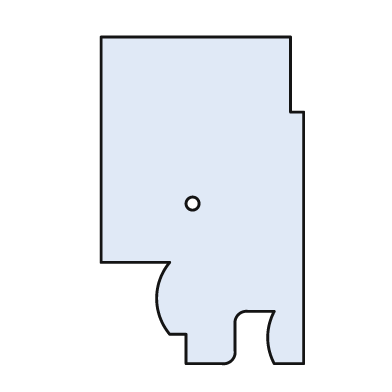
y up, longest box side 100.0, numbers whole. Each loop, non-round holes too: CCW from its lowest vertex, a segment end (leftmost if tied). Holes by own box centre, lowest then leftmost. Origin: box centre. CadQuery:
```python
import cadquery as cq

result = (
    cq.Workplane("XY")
    .moveTo(-5.0, -50.0)
    .lineTo(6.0, -50.0)
    .threePointArc((9.0, -49.0), (10.0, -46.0))
    .lineTo(10.0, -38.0)
    .threePointArc((11.0, -35.0), (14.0, -34.0))
    .lineTo(22.0, -34.0)
    .threePointArc((20.0, -42.0), (22.0, -50.0))
    .lineTo(31.0, -50.0)
    .lineTo(31.0, 27.0)
    .lineTo(27.0, 27.0)
    .lineTo(27.0, 50.0)
    .lineTo(-31.0, 50.0)
    .lineTo(-31.0, -19.0)
    .lineTo(-10.0, -19.0)
    .threePointArc((-14.0, -30.0), (-10.0, -41.0))
    .lineTo(-5.0, -41.0)
    .close()
    .moveTo(-3.0, -1.0)
    .circle(2.0)
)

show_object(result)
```